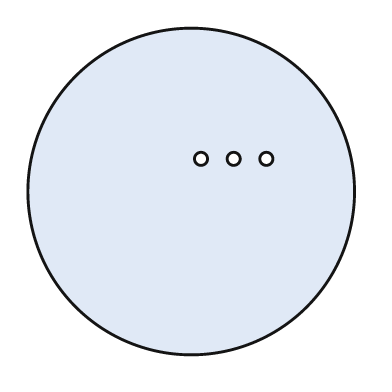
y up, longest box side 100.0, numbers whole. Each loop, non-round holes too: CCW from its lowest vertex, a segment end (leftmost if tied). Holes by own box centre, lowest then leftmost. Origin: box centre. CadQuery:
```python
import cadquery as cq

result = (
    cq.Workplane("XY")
    .moveTo(0.0, 0.0)
    .circle(50.0)
    .moveTo(3.0, 10.0)
    .circle(2.0)
    .moveTo(13.0, 10.0)
    .circle(2.0)
    .moveTo(23.0, 10.0)
    .circle(2.0)
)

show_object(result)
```